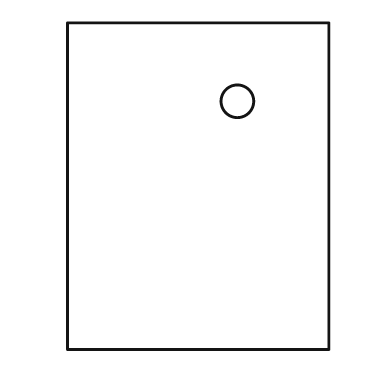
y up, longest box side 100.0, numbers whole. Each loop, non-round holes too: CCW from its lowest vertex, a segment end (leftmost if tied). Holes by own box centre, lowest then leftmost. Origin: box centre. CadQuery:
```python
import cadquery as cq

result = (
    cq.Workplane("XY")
    .moveTo(-40.0, -50.0)
    .lineTo(40.0, -50.0)
    .lineTo(40.0, 50.0)
    .lineTo(-40.0, 50.0)
    .close()
    .moveTo(12.0, 26.0)
    .circle(5.0)
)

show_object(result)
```